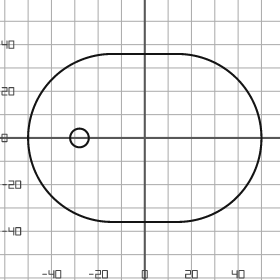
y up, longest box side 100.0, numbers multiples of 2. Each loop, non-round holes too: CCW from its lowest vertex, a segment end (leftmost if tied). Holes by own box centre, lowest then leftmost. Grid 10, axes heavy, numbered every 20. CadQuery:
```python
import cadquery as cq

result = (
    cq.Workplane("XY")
    .moveTo(-14.0, -36.0)
    .lineTo(14.0, -36.0)
    .threePointArc((50.0, 0.0), (14.0, 36.0))
    .lineTo(-14.0, 36.0)
    .threePointArc((-50.0, 0.0), (-14.0, -36.0))
    .close()
    .moveTo(-28.0, 0.0)
    .circle(4.0)
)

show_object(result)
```